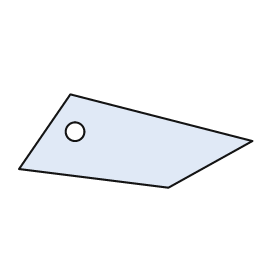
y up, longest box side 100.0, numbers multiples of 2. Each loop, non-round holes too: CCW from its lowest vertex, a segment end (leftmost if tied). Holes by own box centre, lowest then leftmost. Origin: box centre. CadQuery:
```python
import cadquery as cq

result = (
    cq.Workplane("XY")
    .moveTo(14.0, -20.0)
    .lineTo(50.0, 0.0)
    .lineTo(-28.0, 20.0)
    .lineTo(-50.0, -12.0)
    .close()
    .moveTo(-26.0, 4.0)
    .circle(4.0)
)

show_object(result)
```